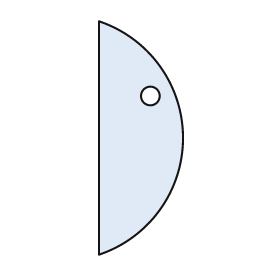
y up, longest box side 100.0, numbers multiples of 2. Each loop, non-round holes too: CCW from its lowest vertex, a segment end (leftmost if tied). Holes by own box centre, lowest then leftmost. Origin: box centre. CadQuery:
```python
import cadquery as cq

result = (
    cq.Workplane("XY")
    .moveTo(-18.0, -50.0)
    .threePointArc((18.0, 0.0), (-18.0, 50.0))
    .close()
    .moveTo(4.0, 18.0)
    .circle(4.0)
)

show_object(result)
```